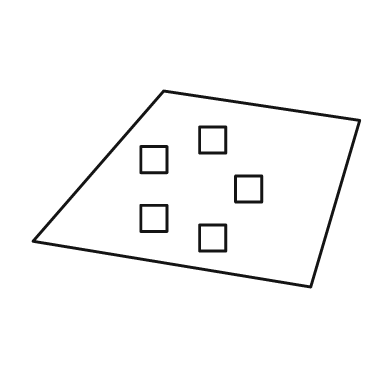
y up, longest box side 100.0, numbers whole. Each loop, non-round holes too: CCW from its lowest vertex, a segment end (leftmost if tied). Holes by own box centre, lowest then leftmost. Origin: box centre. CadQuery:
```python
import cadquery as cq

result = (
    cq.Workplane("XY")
    .moveTo(35.0, -30.0)
    .lineTo(50.0, 21.0)
    .lineTo(-10.0, 30.0)
    .lineTo(-50.0, -16.0)
    .close()
    .moveTo(1.0, -19.0)
    .lineTo(9.0, -19.0)
    .lineTo(9.0, -11.0)
    .lineTo(1.0, -11.0)
    .close()
    .moveTo(-17.0, -13.0)
    .lineTo(-9.0, -13.0)
    .lineTo(-9.0, -5.0)
    .lineTo(-17.0, -5.0)
    .close()
    .moveTo(12.0, -4.0)
    .lineTo(20.0, -4.0)
    .lineTo(20.0, 4.0)
    .lineTo(12.0, 4.0)
    .close()
    .moveTo(-17.0, 5.0)
    .lineTo(-9.0, 5.0)
    .lineTo(-9.0, 13.0)
    .lineTo(-17.0, 13.0)
    .close()
    .moveTo(1.0, 11.0)
    .lineTo(9.0, 11.0)
    .lineTo(9.0, 19.0)
    .lineTo(1.0, 19.0)
    .close()
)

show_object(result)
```